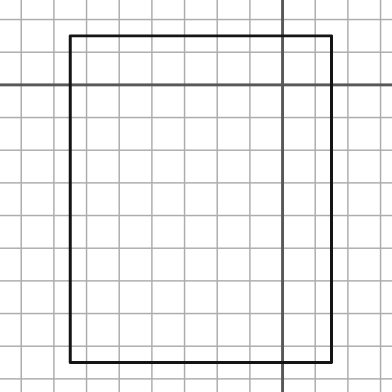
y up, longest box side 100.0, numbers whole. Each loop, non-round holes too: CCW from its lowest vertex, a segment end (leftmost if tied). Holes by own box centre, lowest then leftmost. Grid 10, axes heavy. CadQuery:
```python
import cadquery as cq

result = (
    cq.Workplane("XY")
    .moveTo(-65.0, -85.0)
    .lineTo(15.0, -85.0)
    .lineTo(15.0, 15.0)
    .lineTo(-65.0, 15.0)
    .close()
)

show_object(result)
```